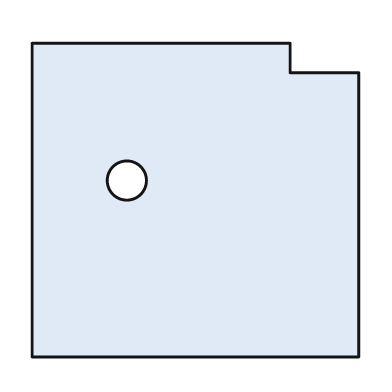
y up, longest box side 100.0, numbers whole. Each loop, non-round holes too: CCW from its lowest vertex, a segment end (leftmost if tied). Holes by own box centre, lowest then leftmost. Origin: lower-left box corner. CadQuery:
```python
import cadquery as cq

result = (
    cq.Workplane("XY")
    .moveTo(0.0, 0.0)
    .lineTo(100.0, 0.0)
    .lineTo(100.0, 87.0)
    .lineTo(79.0, 87.0)
    .lineTo(79.0, 96.0)
    .lineTo(0.0, 96.0)
    .close()
    .moveTo(29.0, 54.0)
    .circle(6.0)
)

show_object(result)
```